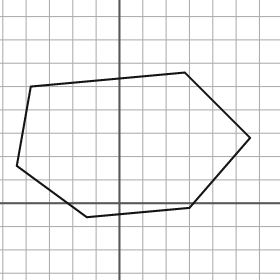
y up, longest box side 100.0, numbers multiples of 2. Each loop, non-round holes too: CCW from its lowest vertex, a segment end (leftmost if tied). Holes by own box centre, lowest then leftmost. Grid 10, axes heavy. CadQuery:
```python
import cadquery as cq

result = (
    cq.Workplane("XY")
    .moveTo(-14.0, -6.0)
    .lineTo(30.0, -2.0)
    .lineTo(56.0, 28.0)
    .lineTo(28.0, 56.0)
    .lineTo(-38.0, 50.0)
    .lineTo(-44.0, 16.0)
    .close()
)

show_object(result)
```